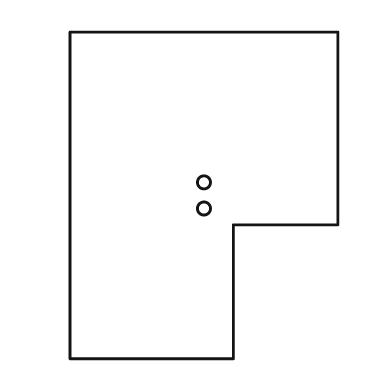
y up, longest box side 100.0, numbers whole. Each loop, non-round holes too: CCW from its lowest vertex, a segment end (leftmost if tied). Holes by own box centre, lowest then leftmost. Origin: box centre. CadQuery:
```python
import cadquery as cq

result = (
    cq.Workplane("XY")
    .moveTo(-41.0, -50.0)
    .lineTo(9.0, -50.0)
    .lineTo(9.0, -9.0)
    .lineTo(41.0, -9.0)
    .lineTo(41.0, 50.0)
    .lineTo(-41.0, 50.0)
    .close()
    .moveTo(0.0, -4.0)
    .circle(2.0)
    .moveTo(0.0, 4.0)
    .circle(2.0)
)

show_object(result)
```